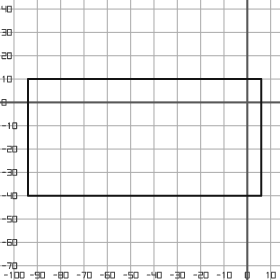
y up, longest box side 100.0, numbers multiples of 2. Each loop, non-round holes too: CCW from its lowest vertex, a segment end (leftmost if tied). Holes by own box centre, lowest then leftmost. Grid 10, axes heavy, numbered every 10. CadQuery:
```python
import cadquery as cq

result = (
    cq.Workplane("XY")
    .moveTo(-94.0, -40.0)
    .lineTo(6.0, -40.0)
    .lineTo(6.0, 10.0)
    .lineTo(-94.0, 10.0)
    .close()
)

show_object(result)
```